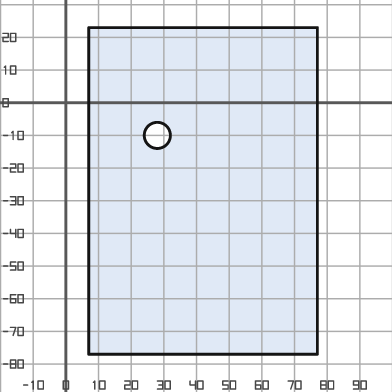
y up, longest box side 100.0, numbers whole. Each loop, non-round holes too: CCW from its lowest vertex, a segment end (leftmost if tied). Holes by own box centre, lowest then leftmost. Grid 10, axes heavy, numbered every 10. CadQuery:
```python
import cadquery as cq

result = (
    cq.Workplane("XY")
    .moveTo(7.0, -77.0)
    .lineTo(77.0, -77.0)
    .lineTo(77.0, 23.0)
    .lineTo(7.0, 23.0)
    .close()
    .moveTo(28.0, -10.0)
    .circle(4.0)
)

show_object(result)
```